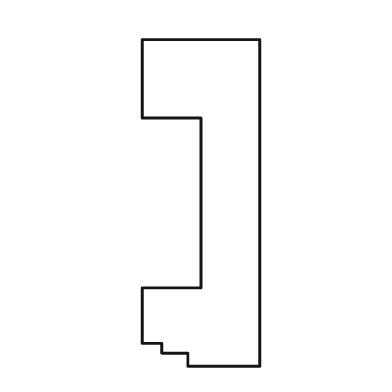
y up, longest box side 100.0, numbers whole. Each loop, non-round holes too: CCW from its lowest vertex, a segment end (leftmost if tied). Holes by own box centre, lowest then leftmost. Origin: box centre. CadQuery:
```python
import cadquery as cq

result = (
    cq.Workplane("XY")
    .moveTo(-4.0, -50.0)
    .lineTo(18.0, -50.0)
    .lineTo(18.0, 50.0)
    .lineTo(-18.0, 50.0)
    .lineTo(-18.0, 26.0)
    .lineTo(0.0, 26.0)
    .lineTo(0.0, -26.0)
    .lineTo(-18.0, -26.0)
    .lineTo(-18.0, -43.0)
    .lineTo(-12.0, -43.0)
    .lineTo(-12.0, -46.0)
    .lineTo(-4.0, -46.0)
    .close()
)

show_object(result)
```